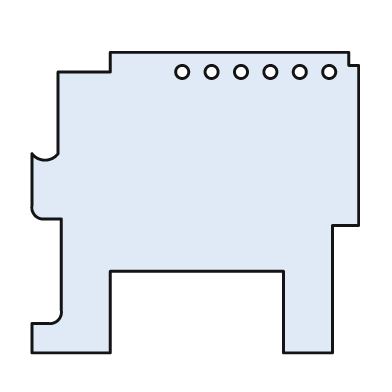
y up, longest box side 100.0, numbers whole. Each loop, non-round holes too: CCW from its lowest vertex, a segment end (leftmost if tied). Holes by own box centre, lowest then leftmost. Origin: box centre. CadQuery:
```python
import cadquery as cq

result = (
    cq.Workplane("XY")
    .moveTo(-50.0, -46.0)
    .lineTo(-26.0, -46.0)
    .lineTo(-26.0, -21.0)
    .lineTo(27.0, -21.0)
    .lineTo(27.0, -46.0)
    .lineTo(42.0, -46.0)
    .lineTo(42.0, -7.0)
    .lineTo(50.0, -7.0)
    .lineTo(50.0, 42.0)
    .lineTo(47.0, 42.0)
    .lineTo(47.0, 46.0)
    .lineTo(-26.0, 46.0)
    .lineTo(-26.0, 40.0)
    .lineTo(-42.0, 40.0)
    .lineTo(-42.0, 15.0)
    .threePointArc((-46.0, 13.0), (-50.0, 15.0))
    .lineTo(-50.0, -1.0)
    .threePointArc((-49.0, -4.0), (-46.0, -5.0))
    .lineTo(-41.0, -5.0)
    .lineTo(-41.0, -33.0)
    .threePointArc((-42.0, -36.0), (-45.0, -37.0))
    .lineTo(-50.0, -37.0)
    .close()
    .moveTo(-4.0, 40.0)
    .circle(2.0)
    .moveTo(5.0, 40.0)
    .circle(2.0)
    .moveTo(14.0, 40.0)
    .circle(2.0)
    .moveTo(23.0, 40.0)
    .circle(2.0)
    .moveTo(32.0, 40.0)
    .circle(2.0)
    .moveTo(41.0, 40.0)
    .circle(2.0)
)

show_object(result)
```